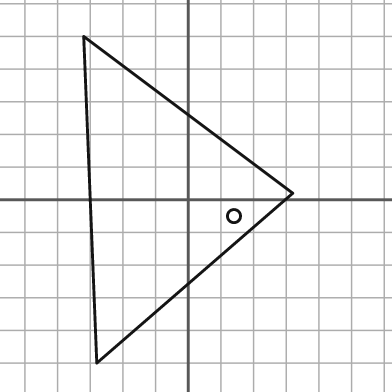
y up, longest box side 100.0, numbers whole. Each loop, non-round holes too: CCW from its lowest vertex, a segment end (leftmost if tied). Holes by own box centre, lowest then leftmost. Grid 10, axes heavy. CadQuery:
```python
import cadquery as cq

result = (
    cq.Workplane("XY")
    .moveTo(-28.0, -50.0)
    .lineTo(32.0, 2.0)
    .lineTo(-32.0, 50.0)
    .close()
    .moveTo(14.0, -5.0)
    .circle(2.0)
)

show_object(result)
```